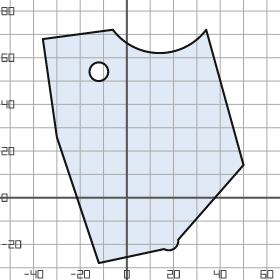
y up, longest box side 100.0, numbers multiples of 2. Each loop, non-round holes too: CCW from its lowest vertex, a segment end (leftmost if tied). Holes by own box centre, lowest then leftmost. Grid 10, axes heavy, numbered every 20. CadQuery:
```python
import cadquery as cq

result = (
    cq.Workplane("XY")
    .moveTo(-12.0, -28.0)
    .lineTo(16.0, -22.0)
    .threePointArc((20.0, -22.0), (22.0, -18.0))
    .lineTo(50.0, 14.0)
    .lineTo(34.0, 72.0)
    .threePointArc((14.0, 62.0), (-6.0, 72.0))
    .lineTo(-36.0, 68.0)
    .lineTo(-30.0, 26.0)
    .close()
    .moveTo(-12.0, 54.0)
    .circle(4.0)
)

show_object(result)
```